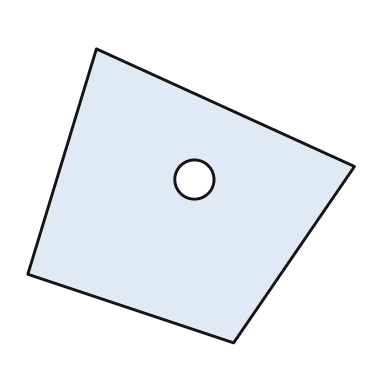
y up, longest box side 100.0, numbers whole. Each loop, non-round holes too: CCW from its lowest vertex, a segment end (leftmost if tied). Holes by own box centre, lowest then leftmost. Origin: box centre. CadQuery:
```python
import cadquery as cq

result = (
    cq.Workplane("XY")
    .moveTo(13.0, -45.0)
    .lineTo(50.0, 9.0)
    .lineTo(-29.0, 45.0)
    .lineTo(-50.0, -24.0)
    .close()
    .moveTo(1.0, 5.0)
    .circle(6.0)
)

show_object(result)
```